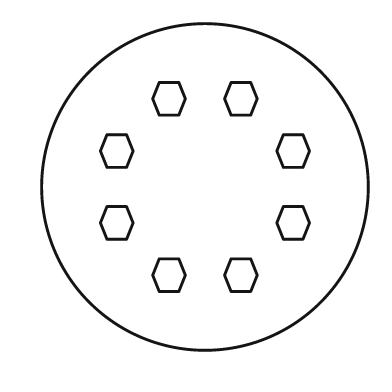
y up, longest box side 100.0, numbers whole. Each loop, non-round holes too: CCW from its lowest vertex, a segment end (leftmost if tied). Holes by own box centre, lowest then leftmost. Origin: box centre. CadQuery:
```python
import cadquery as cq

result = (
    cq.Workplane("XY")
    .moveTo(0.0, 0.0)
    .circle(50.0)
    .moveTo(-14.0, -32.0)
    .lineTo(-8.0, -32.0)
    .lineTo(-6.0, -27.0)
    .lineTo(-8.0, -22.0)
    .lineTo(-14.0, -22.0)
    .lineTo(-16.0, -27.0)
    .close()
    .moveTo(8.0, -32.0)
    .lineTo(14.0, -32.0)
    .lineTo(16.0, -27.0)
    .lineTo(14.0, -22.0)
    .lineTo(8.0, -22.0)
    .lineTo(6.0, -27.0)
    .close()
    .moveTo(-30.0, -16.0)
    .lineTo(-24.0, -16.0)
    .lineTo(-22.0, -11.0)
    .lineTo(-24.0, -6.0)
    .lineTo(-30.0, -6.0)
    .lineTo(-32.0, -11.0)
    .close()
    .moveTo(24.0, -16.0)
    .lineTo(30.0, -16.0)
    .lineTo(32.0, -11.0)
    .lineTo(30.0, -6.0)
    .lineTo(24.0, -6.0)
    .lineTo(22.0, -11.0)
    .close()
    .moveTo(-30.0, 6.0)
    .lineTo(-24.0, 6.0)
    .lineTo(-22.0, 11.0)
    .lineTo(-24.0, 16.0)
    .lineTo(-30.0, 16.0)
    .lineTo(-32.0, 11.0)
    .close()
    .moveTo(24.0, 6.0)
    .lineTo(30.0, 6.0)
    .lineTo(32.0, 11.0)
    .lineTo(30.0, 16.0)
    .lineTo(24.0, 16.0)
    .lineTo(22.0, 11.0)
    .close()
    .moveTo(-14.0, 22.0)
    .lineTo(-8.0, 22.0)
    .lineTo(-6.0, 27.0)
    .lineTo(-8.0, 32.0)
    .lineTo(-14.0, 32.0)
    .lineTo(-16.0, 27.0)
    .close()
    .moveTo(8.0, 22.0)
    .lineTo(14.0, 22.0)
    .lineTo(16.0, 27.0)
    .lineTo(14.0, 32.0)
    .lineTo(8.0, 32.0)
    .lineTo(6.0, 27.0)
    .close()
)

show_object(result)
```